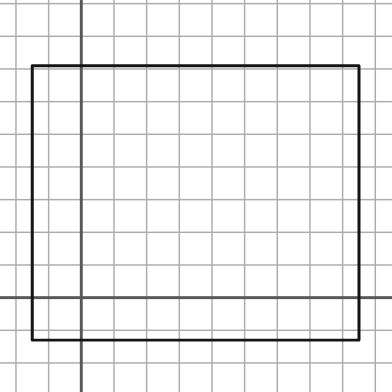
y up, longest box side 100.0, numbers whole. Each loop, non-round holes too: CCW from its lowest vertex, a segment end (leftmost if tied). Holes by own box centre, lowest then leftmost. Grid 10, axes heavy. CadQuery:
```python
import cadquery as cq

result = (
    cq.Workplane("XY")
    .moveTo(-15.0, -13.0)
    .lineTo(85.0, -13.0)
    .lineTo(85.0, 71.0)
    .lineTo(-15.0, 71.0)
    .close()
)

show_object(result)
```